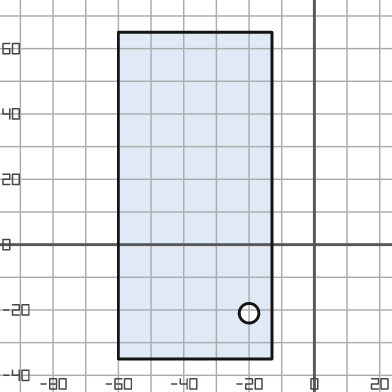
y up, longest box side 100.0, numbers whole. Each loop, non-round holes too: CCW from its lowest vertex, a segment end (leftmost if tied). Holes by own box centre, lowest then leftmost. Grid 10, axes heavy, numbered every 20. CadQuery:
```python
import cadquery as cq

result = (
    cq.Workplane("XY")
    .moveTo(-60.0, -35.0)
    .lineTo(-13.0, -35.0)
    .lineTo(-13.0, 65.0)
    .lineTo(-60.0, 65.0)
    .close()
    .moveTo(-20.0, -21.0)
    .circle(3.0)
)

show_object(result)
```